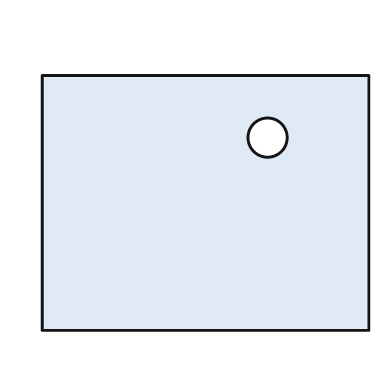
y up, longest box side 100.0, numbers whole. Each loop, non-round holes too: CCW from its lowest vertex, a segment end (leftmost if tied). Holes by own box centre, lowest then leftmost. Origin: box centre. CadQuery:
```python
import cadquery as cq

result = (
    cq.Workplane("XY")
    .moveTo(-50.0, -39.0)
    .lineTo(50.0, -39.0)
    .lineTo(50.0, 39.0)
    .lineTo(-50.0, 39.0)
    .close()
    .moveTo(19.0, 20.0)
    .circle(6.0)
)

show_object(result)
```